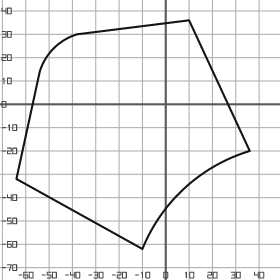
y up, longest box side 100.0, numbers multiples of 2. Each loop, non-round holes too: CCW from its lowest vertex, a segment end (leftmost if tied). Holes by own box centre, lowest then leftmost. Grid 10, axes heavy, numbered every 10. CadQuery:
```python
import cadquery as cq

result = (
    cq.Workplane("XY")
    .moveTo(-10.0, -62.0)
    .threePointArc((8.0, -36.0), (36.0, -20.0))
    .lineTo(10.0, 36.0)
    .lineTo(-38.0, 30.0)
    .threePointArc((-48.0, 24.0), (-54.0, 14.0))
    .lineTo(-64.0, -32.0)
    .close()
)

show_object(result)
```